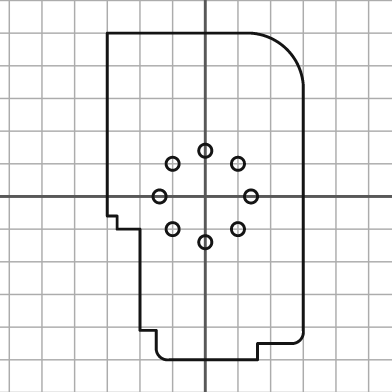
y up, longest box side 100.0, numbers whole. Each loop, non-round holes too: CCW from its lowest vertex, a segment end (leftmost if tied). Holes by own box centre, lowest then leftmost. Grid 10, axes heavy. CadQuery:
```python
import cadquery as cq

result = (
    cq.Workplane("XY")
    .moveTo(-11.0, -50.0)
    .lineTo(16.0, -50.0)
    .lineTo(16.0, -45.0)
    .lineTo(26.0, -45.0)
    .threePointArc((29.0, -44.0), (30.0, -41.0))
    .lineTo(30.0, 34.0)
    .threePointArc((25.0, 45.0), (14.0, 50.0))
    .lineTo(-30.0, 50.0)
    .lineTo(-30.0, -6.0)
    .lineTo(-27.0, -6.0)
    .lineTo(-27.0, -10.0)
    .lineTo(-20.0, -10.0)
    .lineTo(-20.0, -41.0)
    .lineTo(-15.0, -41.0)
    .lineTo(-15.0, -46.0)
    .threePointArc((-14.0, -49.0), (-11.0, -50.0))
    .close()
    .moveTo(0.0, -14.0)
    .circle(2.0)
    .moveTo(-10.0, -10.0)
    .circle(2.0)
    .moveTo(10.0, -10.0)
    .circle(2.0)
    .moveTo(-14.0, 0.0)
    .circle(2.0)
    .moveTo(14.0, 0.0)
    .circle(2.0)
    .moveTo(-10.0, 10.0)
    .circle(2.0)
    .moveTo(10.0, 10.0)
    .circle(2.0)
    .moveTo(0.0, 14.0)
    .circle(2.0)
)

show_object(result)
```